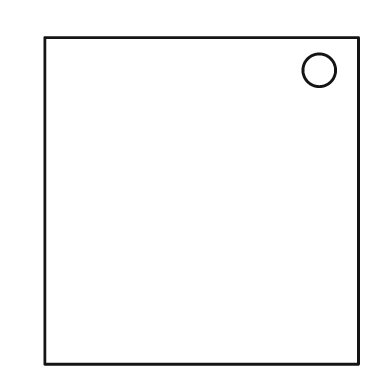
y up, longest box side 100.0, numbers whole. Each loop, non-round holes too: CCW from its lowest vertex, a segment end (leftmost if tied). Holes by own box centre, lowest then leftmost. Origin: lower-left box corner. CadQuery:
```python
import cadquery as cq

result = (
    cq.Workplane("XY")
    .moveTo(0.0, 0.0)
    .lineTo(96.0, 0.0)
    .lineTo(96.0, 100.0)
    .lineTo(0.0, 100.0)
    .close()
    .moveTo(84.0, 90.0)
    .circle(5.0)
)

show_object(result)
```